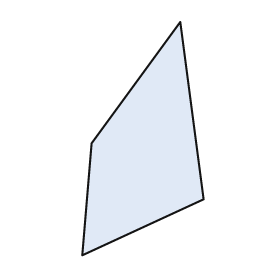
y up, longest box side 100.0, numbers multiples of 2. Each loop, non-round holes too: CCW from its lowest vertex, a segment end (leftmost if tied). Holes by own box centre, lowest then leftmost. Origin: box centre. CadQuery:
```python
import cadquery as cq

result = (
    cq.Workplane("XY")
    .moveTo(-26.0, -50.0)
    .lineTo(26.0, -26.0)
    .lineTo(16.0, 50.0)
    .lineTo(-22.0, -2.0)
    .close()
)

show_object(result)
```